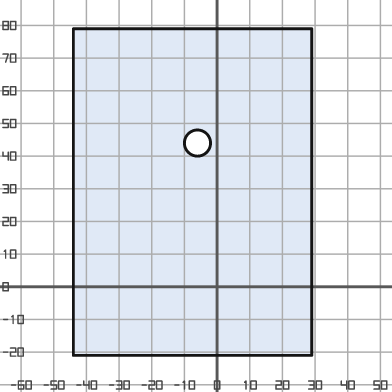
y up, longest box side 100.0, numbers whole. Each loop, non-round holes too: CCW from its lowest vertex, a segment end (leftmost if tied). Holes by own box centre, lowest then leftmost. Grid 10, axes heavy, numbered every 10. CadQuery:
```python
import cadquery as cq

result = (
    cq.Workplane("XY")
    .moveTo(-44.0, -21.0)
    .lineTo(29.0, -21.0)
    .lineTo(29.0, 79.0)
    .lineTo(-44.0, 79.0)
    .close()
    .moveTo(-6.0, 44.0)
    .circle(4.0)
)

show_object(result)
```